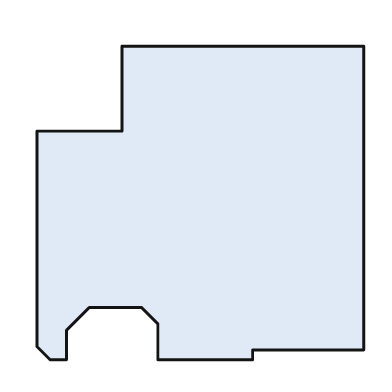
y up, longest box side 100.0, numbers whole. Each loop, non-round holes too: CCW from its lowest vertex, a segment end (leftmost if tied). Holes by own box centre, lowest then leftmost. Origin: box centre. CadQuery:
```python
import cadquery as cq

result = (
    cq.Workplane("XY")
    .moveTo(-46.0, -48.0)
    .lineTo(-41.0, -48.0)
    .lineTo(-41.0, -39.0)
    .lineTo(-34.0, -32.0)
    .lineTo(-18.0, -32.0)
    .lineTo(-13.0, -37.0)
    .lineTo(-13.0, -48.0)
    .lineTo(16.0, -48.0)
    .lineTo(16.0, -45.0)
    .lineTo(50.0, -45.0)
    .lineTo(50.0, 48.0)
    .lineTo(-24.0, 48.0)
    .lineTo(-24.0, 22.0)
    .lineTo(-50.0, 22.0)
    .lineTo(-50.0, -44.0)
    .close()
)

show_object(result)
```